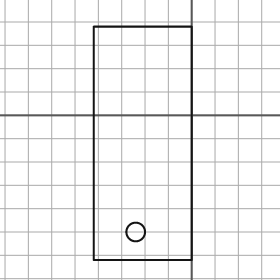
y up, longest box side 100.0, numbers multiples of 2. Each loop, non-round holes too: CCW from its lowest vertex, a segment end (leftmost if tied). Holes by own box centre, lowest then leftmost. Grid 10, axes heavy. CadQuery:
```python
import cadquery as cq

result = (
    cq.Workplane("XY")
    .moveTo(-42.0, -62.0)
    .lineTo(0.0, -62.0)
    .lineTo(0.0, 38.0)
    .lineTo(-42.0, 38.0)
    .close()
    .moveTo(-24.0, -50.0)
    .circle(4.0)
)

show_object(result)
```